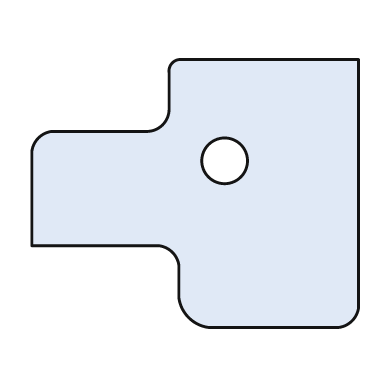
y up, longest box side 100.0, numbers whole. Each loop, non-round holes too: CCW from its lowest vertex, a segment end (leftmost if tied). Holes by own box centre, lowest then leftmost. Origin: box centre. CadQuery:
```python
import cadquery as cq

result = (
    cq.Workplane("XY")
    .moveTo(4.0, -41.0)
    .lineTo(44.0, -41.0)
    .threePointArc((48.0, -39.0), (50.0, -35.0))
    .lineTo(50.0, 41.0)
    .lineTo(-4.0, 41.0)
    .threePointArc((-7.0, 40.0), (-8.0, 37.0))
    .lineTo(-8.0, 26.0)
    .threePointArc((-10.0, 21.0), (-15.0, 19.0))
    .lineTo(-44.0, 19.0)
    .threePointArc((-48.0, 17.0), (-50.0, 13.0))
    .lineTo(-50.0, -16.0)
    .lineTo(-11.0, -16.0)
    .threePointArc((-7.0, -18.0), (-5.0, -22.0))
    .lineTo(-5.0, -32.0)
    .threePointArc((-2.0, -38.0), (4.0, -41.0))
    .close()
    .moveTo(9.0, 10.0)
    .circle(7.0)
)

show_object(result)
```